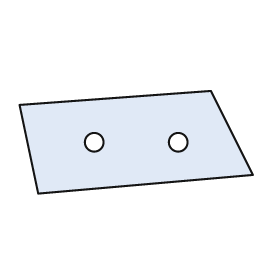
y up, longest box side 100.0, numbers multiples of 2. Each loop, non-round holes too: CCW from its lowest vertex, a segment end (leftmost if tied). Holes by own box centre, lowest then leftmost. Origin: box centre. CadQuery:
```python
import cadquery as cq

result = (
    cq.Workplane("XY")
    .moveTo(-42.0, -22.0)
    .lineTo(50.0, -14.0)
    .lineTo(32.0, 22.0)
    .lineTo(-50.0, 16.0)
    .close()
    .moveTo(-18.0, 0.0)
    .circle(4.0)
    .moveTo(18.0, 0.0)
    .circle(4.0)
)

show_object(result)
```